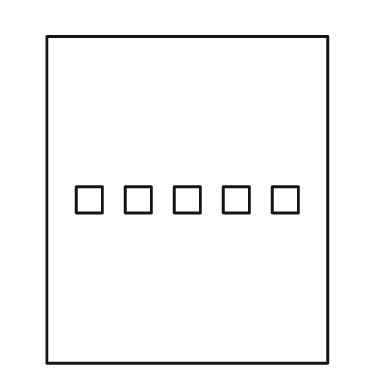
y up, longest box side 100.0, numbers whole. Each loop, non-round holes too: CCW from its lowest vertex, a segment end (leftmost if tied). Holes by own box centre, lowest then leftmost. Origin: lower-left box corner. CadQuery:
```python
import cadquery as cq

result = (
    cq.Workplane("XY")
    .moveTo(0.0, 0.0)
    .lineTo(86.0, 0.0)
    .lineTo(86.0, 100.0)
    .lineTo(0.0, 100.0)
    .close()
    .moveTo(9.0, 46.0)
    .lineTo(17.0, 46.0)
    .lineTo(17.0, 54.0)
    .lineTo(9.0, 54.0)
    .close()
    .moveTo(24.0, 46.0)
    .lineTo(32.0, 46.0)
    .lineTo(32.0, 54.0)
    .lineTo(24.0, 54.0)
    .close()
    .moveTo(39.0, 46.0)
    .lineTo(47.0, 46.0)
    .lineTo(47.0, 54.0)
    .lineTo(39.0, 54.0)
    .close()
    .moveTo(54.0, 46.0)
    .lineTo(62.0, 46.0)
    .lineTo(62.0, 54.0)
    .lineTo(54.0, 54.0)
    .close()
    .moveTo(69.0, 46.0)
    .lineTo(77.0, 46.0)
    .lineTo(77.0, 54.0)
    .lineTo(69.0, 54.0)
    .close()
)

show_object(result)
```